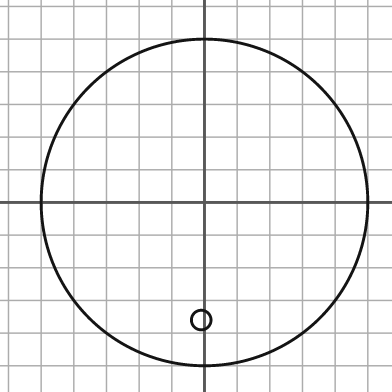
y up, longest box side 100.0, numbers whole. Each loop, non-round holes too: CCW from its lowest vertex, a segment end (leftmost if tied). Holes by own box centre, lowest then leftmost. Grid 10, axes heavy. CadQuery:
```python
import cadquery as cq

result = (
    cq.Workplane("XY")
    .moveTo(0.0, 0.0)
    .circle(50.0)
    .moveTo(-1.0, -36.0)
    .circle(3.0)
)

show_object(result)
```